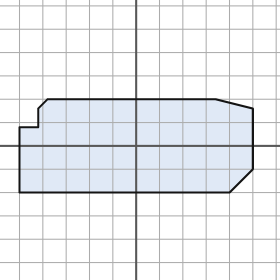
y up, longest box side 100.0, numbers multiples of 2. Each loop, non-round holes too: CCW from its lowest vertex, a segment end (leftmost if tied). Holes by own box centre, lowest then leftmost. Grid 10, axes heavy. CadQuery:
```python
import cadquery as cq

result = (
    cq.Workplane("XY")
    .moveTo(-50.0, -20.0)
    .lineTo(40.0, -20.0)
    .lineTo(50.0, -10.0)
    .lineTo(50.0, 16.0)
    .lineTo(34.0, 20.0)
    .lineTo(-38.0, 20.0)
    .lineTo(-42.0, 16.0)
    .lineTo(-42.0, 8.0)
    .lineTo(-50.0, 8.0)
    .close()
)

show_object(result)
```